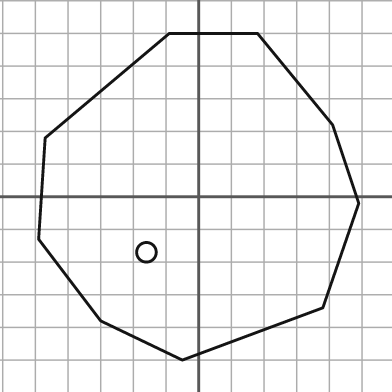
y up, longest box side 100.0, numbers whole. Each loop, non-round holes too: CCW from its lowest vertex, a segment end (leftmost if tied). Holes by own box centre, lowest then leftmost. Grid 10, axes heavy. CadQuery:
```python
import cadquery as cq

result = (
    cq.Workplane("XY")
    .moveTo(-5.0, -50.0)
    .lineTo(38.0, -34.0)
    .lineTo(49.0, -2.0)
    .lineTo(41.0, 22.0)
    .lineTo(18.0, 50.0)
    .lineTo(-9.0, 50.0)
    .lineTo(-47.0, 18.0)
    .lineTo(-49.0, -13.0)
    .lineTo(-30.0, -38.0)
    .close()
    .moveTo(-16.0, -17.0)
    .circle(3.0)
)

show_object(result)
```